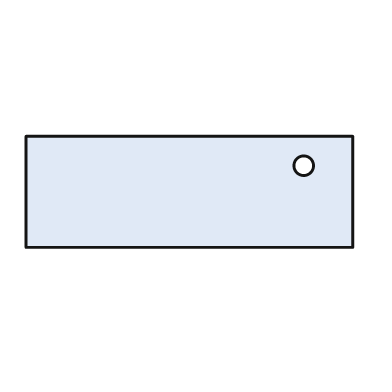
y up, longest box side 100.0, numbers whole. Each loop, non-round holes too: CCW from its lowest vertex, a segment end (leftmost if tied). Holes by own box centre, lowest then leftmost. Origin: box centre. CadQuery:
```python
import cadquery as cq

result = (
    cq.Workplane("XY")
    .moveTo(-50.0, -17.0)
    .lineTo(50.0, -17.0)
    .lineTo(50.0, 17.0)
    .lineTo(-50.0, 17.0)
    .close()
    .moveTo(35.0, 8.0)
    .circle(3.0)
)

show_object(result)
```